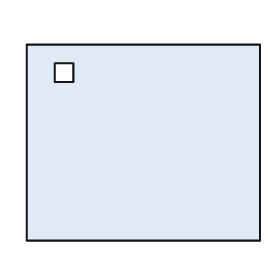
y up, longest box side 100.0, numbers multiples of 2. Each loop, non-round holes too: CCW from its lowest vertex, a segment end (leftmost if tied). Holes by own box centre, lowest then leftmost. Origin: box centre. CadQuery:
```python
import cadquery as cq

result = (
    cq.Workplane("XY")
    .moveTo(-50.0, -42.0)
    .lineTo(50.0, -42.0)
    .lineTo(50.0, 42.0)
    .lineTo(-50.0, 42.0)
    .close()
    .moveTo(-38.0, 26.0)
    .lineTo(-30.0, 26.0)
    .lineTo(-30.0, 34.0)
    .lineTo(-38.0, 34.0)
    .close()
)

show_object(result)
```